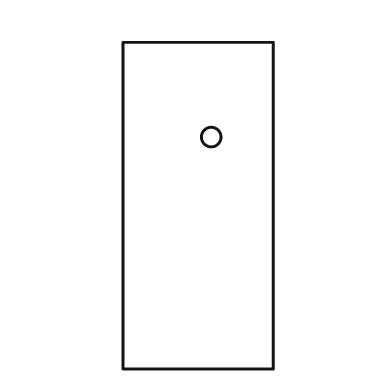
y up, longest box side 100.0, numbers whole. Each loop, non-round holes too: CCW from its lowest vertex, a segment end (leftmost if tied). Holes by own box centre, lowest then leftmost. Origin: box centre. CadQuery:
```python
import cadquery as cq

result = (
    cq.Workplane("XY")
    .moveTo(-23.0, -50.0)
    .lineTo(23.0, -50.0)
    .lineTo(23.0, 50.0)
    .lineTo(-23.0, 50.0)
    .close()
    .moveTo(4.0, 21.0)
    .circle(3.0)
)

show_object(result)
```